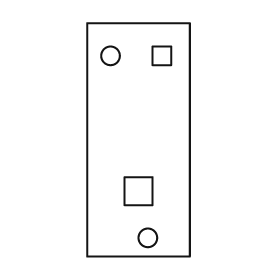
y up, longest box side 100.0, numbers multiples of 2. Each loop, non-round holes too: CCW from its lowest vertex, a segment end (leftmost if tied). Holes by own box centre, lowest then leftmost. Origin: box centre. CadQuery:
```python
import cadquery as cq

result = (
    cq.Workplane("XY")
    .moveTo(-22.0, -50.0)
    .lineTo(22.0, -50.0)
    .lineTo(22.0, 50.0)
    .lineTo(-22.0, 50.0)
    .close()
    .moveTo(4.0, -42.0)
    .circle(4.0)
    .moveTo(-6.0, -28.0)
    .lineTo(6.0, -28.0)
    .lineTo(6.0, -16.0)
    .lineTo(-6.0, -16.0)
    .close()
    .moveTo(-12.0, 36.0)
    .circle(4.0)
    .moveTo(6.0, 32.0)
    .lineTo(14.0, 32.0)
    .lineTo(14.0, 40.0)
    .lineTo(6.0, 40.0)
    .close()
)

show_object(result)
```